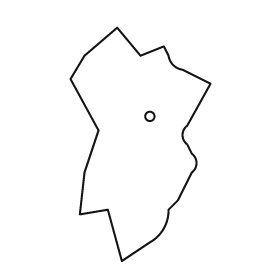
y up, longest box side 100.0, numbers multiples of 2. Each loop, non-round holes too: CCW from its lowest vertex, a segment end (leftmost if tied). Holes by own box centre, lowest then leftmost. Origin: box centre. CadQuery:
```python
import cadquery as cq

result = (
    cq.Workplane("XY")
    .moveTo(-8.0, -50.0)
    .lineTo(4.0, -42.0)
    .threePointArc((10.0, -36.0), (12.0, -28.0))
    .lineTo(16.0, -24.0)
    .lineTo(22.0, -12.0)
    .threePointArc((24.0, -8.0), (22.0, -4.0))
    .lineTo(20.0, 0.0)
    .threePointArc((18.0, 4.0), (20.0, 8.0))
    .lineTo(30.0, 26.0)
    .lineTo(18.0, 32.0)
    .threePointArc((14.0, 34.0), (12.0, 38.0))
    .lineTo(10.0, 42.0)
    .lineTo(0.0, 38.0)
    .lineTo(-10.0, 50.0)
    .lineTo(-24.0, 38.0)
    .lineTo(-30.0, 28.0)
    .lineTo(-18.0, 6.0)
    .lineTo(-24.0, -12.0)
    .lineTo(-26.0, -30.0)
    .lineTo(-14.0, -28.0)
    .close()
    .moveTo(4.0, 12.0)
    .circle(2.0)
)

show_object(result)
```